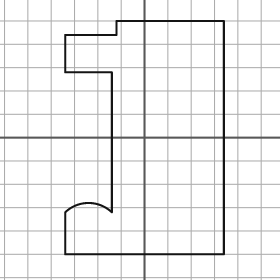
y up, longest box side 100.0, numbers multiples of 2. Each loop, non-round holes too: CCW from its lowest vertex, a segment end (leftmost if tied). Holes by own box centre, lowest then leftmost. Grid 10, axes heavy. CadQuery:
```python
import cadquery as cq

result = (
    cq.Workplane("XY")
    .moveTo(-34.0, -50.0)
    .lineTo(34.0, -50.0)
    .lineTo(34.0, 50.0)
    .lineTo(-12.0, 50.0)
    .lineTo(-12.0, 44.0)
    .lineTo(-34.0, 44.0)
    .lineTo(-34.0, 28.0)
    .lineTo(-14.0, 28.0)
    .lineTo(-14.0, -32.0)
    .threePointArc((-24.0, -28.0), (-34.0, -32.0))
    .close()
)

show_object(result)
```